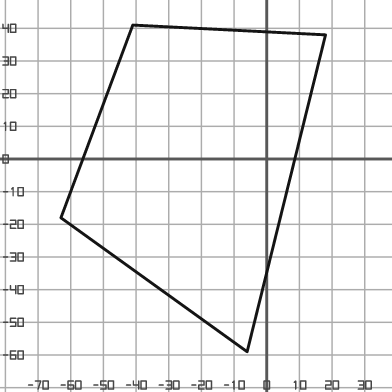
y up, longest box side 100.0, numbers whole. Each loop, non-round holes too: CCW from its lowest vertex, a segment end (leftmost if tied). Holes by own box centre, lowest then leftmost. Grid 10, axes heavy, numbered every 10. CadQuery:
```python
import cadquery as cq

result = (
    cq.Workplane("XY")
    .moveTo(-6.0, -59.0)
    .lineTo(18.0, 38.0)
    .lineTo(-41.0, 41.0)
    .lineTo(-63.0, -18.0)
    .close()
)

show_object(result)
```